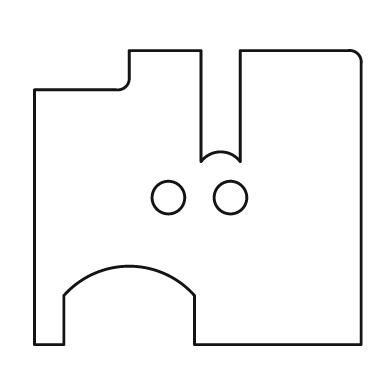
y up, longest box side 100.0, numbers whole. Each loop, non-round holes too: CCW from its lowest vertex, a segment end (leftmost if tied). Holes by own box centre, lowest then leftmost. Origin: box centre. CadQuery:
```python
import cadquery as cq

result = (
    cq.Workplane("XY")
    .moveTo(-50.0, -45.0)
    .lineTo(-41.0, -45.0)
    .lineTo(-41.0, -30.0)
    .threePointArc((-21.0, -21.0), (-1.0, -30.0))
    .lineTo(-1.0, -45.0)
    .lineTo(50.0, -45.0)
    .lineTo(50.0, 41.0)
    .threePointArc((49.0, 44.0), (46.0, 45.0))
    .lineTo(13.0, 45.0)
    .lineTo(13.0, 11.0)
    .threePointArc((7.0, 14.0), (1.0, 11.0))
    .lineTo(1.0, 45.0)
    .lineTo(-21.0, 45.0)
    .lineTo(-21.0, 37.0)
    .threePointArc((-22.0, 34.0), (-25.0, 33.0))
    .lineTo(-50.0, 33.0)
    .close()
    .moveTo(-9.0, 0.0)
    .circle(5.0)
    .moveTo(10.0, 0.0)
    .circle(5.0)
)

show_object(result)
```